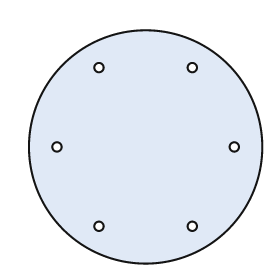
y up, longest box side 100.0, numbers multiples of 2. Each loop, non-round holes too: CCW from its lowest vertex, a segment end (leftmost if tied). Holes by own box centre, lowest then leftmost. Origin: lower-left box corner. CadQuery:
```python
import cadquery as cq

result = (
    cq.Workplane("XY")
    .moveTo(50.0, 50.0)
    .circle(50.0)
    .moveTo(30.0, 16.0)
    .circle(2.0)
    .moveTo(70.0, 16.0)
    .circle(2.0)
    .moveTo(12.0, 50.0)
    .circle(2.0)
    .moveTo(88.0, 50.0)
    .circle(2.0)
    .moveTo(30.0, 84.0)
    .circle(2.0)
    .moveTo(70.0, 84.0)
    .circle(2.0)
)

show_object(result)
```